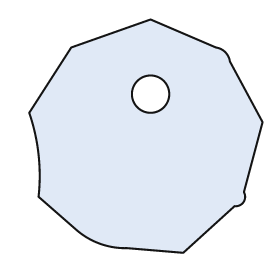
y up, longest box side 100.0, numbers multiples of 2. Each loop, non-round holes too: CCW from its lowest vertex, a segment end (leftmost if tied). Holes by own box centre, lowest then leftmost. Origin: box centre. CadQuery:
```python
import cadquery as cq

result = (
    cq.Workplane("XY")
    .moveTo(16.0, -50.0)
    .lineTo(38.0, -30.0)
    .threePointArc((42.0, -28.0), (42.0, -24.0))
    .lineTo(50.0, 6.0)
    .lineTo(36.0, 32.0)
    .threePointArc((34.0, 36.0), (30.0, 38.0))
    .lineTo(2.0, 50.0)
    .lineTo(-32.0, 38.0)
    .lineTo(-50.0, 10.0)
    .threePointArc((-46.0, -8.0), (-46.0, -26.0))
    .lineTo(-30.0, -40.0)
    .threePointArc((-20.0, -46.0), (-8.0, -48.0))
    .close()
    .moveTo(2.0, 18.0)
    .circle(8.0)
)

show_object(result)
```